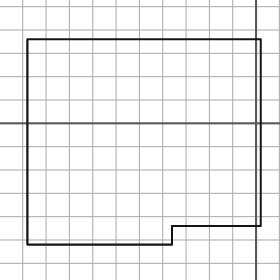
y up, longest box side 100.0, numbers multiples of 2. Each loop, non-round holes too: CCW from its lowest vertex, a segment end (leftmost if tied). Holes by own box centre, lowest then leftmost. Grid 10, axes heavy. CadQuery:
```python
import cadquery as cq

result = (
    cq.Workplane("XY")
    .moveTo(-98.0, -52.0)
    .lineTo(-36.0, -52.0)
    .lineTo(-36.0, -44.0)
    .lineTo(2.0, -44.0)
    .lineTo(2.0, 36.0)
    .lineTo(-98.0, 36.0)
    .close()
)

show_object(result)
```